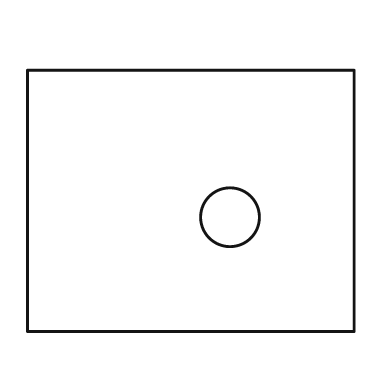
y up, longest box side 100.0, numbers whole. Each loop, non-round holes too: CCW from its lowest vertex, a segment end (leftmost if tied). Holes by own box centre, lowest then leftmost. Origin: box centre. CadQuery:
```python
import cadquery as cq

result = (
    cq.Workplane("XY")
    .moveTo(-50.0, -40.0)
    .lineTo(50.0, -40.0)
    .lineTo(50.0, 40.0)
    .lineTo(-50.0, 40.0)
    .close()
    .moveTo(12.0, -5.0)
    .circle(9.0)
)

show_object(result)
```